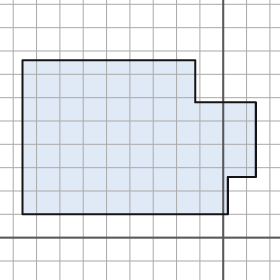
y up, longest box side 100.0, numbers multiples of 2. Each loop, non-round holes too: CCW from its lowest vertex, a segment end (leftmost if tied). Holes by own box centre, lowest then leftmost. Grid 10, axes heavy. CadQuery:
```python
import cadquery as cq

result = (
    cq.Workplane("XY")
    .moveTo(-86.0, 10.0)
    .lineTo(2.0, 10.0)
    .lineTo(2.0, 26.0)
    .lineTo(14.0, 26.0)
    .lineTo(14.0, 58.0)
    .lineTo(-12.0, 58.0)
    .lineTo(-12.0, 76.0)
    .lineTo(-86.0, 76.0)
    .close()
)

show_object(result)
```